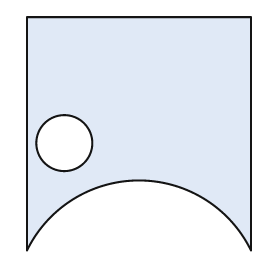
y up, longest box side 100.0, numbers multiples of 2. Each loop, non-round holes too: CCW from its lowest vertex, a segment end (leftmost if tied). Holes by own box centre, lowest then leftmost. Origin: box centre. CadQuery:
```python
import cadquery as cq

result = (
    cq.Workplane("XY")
    .moveTo(-48.0, -50.0)
    .threePointArc((0.0, -20.0), (48.0, -50.0))
    .lineTo(48.0, 50.0)
    .lineTo(-48.0, 50.0)
    .close()
    .moveTo(-32.0, -4.0)
    .circle(12.0)
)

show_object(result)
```